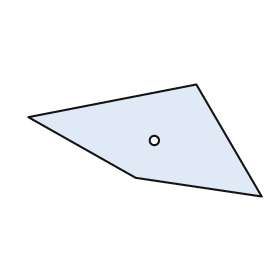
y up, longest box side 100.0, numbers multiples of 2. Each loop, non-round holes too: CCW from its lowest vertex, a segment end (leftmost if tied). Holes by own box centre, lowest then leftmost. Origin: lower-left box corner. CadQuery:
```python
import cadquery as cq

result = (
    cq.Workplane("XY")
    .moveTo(100.0, 0.0)
    .lineTo(72.0, 48.0)
    .lineTo(0.0, 34.0)
    .lineTo(46.0, 8.0)
    .close()
    .moveTo(54.0, 24.0)
    .circle(2.0)
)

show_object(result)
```